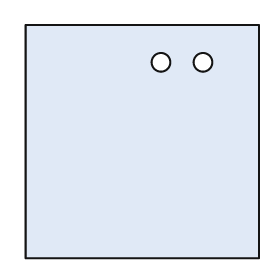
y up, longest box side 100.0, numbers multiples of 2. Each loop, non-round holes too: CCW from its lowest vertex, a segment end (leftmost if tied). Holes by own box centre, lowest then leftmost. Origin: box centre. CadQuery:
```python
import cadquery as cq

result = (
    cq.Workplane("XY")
    .moveTo(-50.0, -50.0)
    .lineTo(50.0, -50.0)
    .lineTo(50.0, 50.0)
    .lineTo(-50.0, 50.0)
    .close()
    .moveTo(8.0, 34.0)
    .circle(4.0)
    .moveTo(26.0, 34.0)
    .circle(4.0)
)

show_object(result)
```